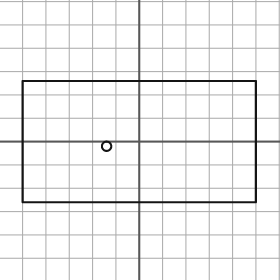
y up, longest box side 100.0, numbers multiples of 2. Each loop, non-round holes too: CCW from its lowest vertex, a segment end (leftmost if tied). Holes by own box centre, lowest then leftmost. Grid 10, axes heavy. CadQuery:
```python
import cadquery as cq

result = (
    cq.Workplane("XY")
    .moveTo(-50.0, -26.0)
    .lineTo(50.0, -26.0)
    .lineTo(50.0, 26.0)
    .lineTo(-50.0, 26.0)
    .close()
    .moveTo(-14.0, -2.0)
    .circle(2.0)
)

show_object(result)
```